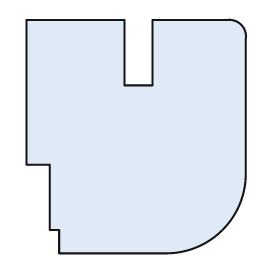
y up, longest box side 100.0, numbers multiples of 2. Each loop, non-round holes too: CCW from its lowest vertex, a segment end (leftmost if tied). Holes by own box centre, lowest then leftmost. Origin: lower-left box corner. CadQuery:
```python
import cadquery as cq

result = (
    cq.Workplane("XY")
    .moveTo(14.0, 0.0)
    .lineTo(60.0, 0.0)
    .threePointArc((84.0, 10.0), (94.0, 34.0))
    .lineTo(94.0, 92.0)
    .threePointArc((92.0, 98.0), (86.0, 100.0))
    .lineTo(54.0, 100.0)
    .lineTo(54.0, 72.0)
    .lineTo(42.0, 72.0)
    .lineTo(42.0, 100.0)
    .lineTo(0.0, 100.0)
    .lineTo(0.0, 38.0)
    .lineTo(10.0, 38.0)
    .lineTo(10.0, 10.0)
    .lineTo(14.0, 10.0)
    .close()
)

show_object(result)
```